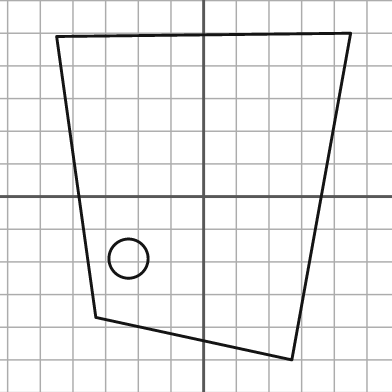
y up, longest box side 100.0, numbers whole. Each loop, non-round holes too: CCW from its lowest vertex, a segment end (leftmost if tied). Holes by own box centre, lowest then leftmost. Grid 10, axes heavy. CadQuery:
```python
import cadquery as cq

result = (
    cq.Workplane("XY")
    .moveTo(27.0, -50.0)
    .lineTo(45.0, 50.0)
    .lineTo(-45.0, 49.0)
    .lineTo(-33.0, -37.0)
    .close()
    .moveTo(-23.0, -19.0)
    .circle(6.0)
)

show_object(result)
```